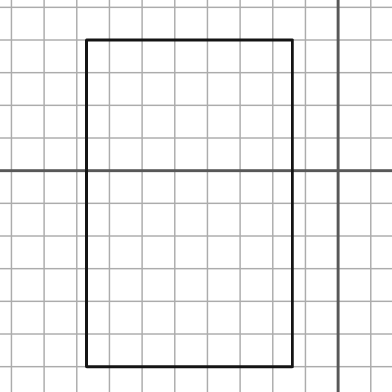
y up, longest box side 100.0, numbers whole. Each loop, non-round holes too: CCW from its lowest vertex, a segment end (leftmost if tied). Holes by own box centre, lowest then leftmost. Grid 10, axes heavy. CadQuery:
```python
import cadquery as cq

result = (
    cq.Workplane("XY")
    .moveTo(-77.0, -60.0)
    .lineTo(-14.0, -60.0)
    .lineTo(-14.0, 40.0)
    .lineTo(-77.0, 40.0)
    .close()
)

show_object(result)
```